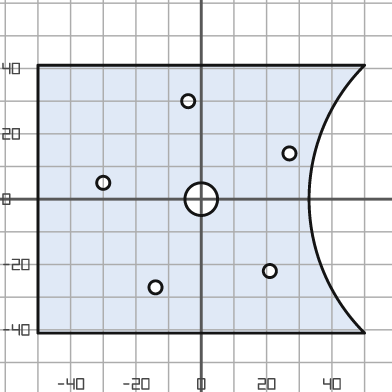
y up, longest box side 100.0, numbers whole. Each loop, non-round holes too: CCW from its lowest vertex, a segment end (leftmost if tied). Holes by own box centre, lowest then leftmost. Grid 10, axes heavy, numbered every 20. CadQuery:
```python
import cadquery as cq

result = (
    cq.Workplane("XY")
    .moveTo(-50.0, -41.0)
    .lineTo(50.0, -41.0)
    .threePointArc((33.0, 0.0), (50.0, 41.0))
    .lineTo(-50.0, 41.0)
    .close()
    .moveTo(-14.0, -27.0)
    .circle(2.0)
    .moveTo(21.0, -22.0)
    .circle(2.0)
    .moveTo(0.0, 0.0)
    .circle(5.0)
    .moveTo(-30.0, 5.0)
    .circle(2.0)
    .moveTo(27.0, 14.0)
    .circle(2.0)
    .moveTo(-4.0, 30.0)
    .circle(2.0)
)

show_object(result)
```